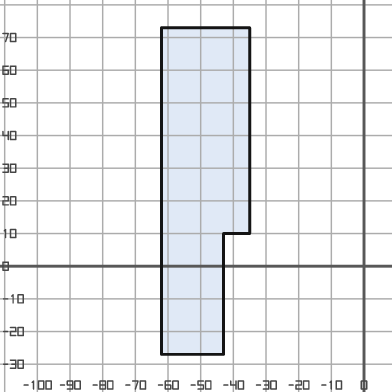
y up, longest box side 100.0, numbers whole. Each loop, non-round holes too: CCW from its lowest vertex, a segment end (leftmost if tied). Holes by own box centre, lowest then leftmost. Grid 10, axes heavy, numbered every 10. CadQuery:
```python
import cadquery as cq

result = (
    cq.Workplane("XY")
    .moveTo(-62.0, -27.0)
    .lineTo(-43.0, -27.0)
    .lineTo(-43.0, 10.0)
    .lineTo(-35.0, 10.0)
    .lineTo(-35.0, 73.0)
    .lineTo(-62.0, 73.0)
    .close()
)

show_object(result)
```